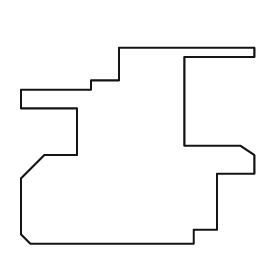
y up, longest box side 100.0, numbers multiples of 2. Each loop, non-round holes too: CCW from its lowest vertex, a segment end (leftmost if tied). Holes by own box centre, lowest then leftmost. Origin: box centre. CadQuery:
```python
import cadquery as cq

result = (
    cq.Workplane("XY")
    .moveTo(-46.0, -42.0)
    .lineTo(24.0, -42.0)
    .lineTo(24.0, -36.0)
    .lineTo(34.0, -36.0)
    .lineTo(34.0, -12.0)
    .lineTo(50.0, -12.0)
    .lineTo(50.0, -4.0)
    .lineTo(44.0, 0.0)
    .lineTo(20.0, 0.0)
    .lineTo(20.0, 38.0)
    .lineTo(50.0, 38.0)
    .lineTo(50.0, 42.0)
    .lineTo(-8.0, 42.0)
    .lineTo(-8.0, 28.0)
    .lineTo(-20.0, 28.0)
    .lineTo(-20.0, 24.0)
    .lineTo(-50.0, 24.0)
    .lineTo(-50.0, 16.0)
    .lineTo(-26.0, 16.0)
    .lineTo(-26.0, -4.0)
    .lineTo(-40.0, -4.0)
    .lineTo(-50.0, -14.0)
    .lineTo(-50.0, -38.0)
    .close()
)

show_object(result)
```